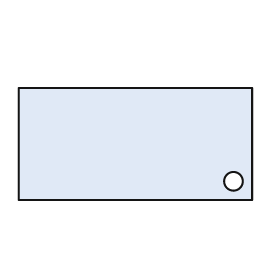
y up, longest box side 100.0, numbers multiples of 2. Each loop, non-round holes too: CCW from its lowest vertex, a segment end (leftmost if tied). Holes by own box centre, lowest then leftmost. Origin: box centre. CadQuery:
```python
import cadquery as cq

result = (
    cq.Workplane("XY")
    .moveTo(-50.0, -24.0)
    .lineTo(50.0, -24.0)
    .lineTo(50.0, 24.0)
    .lineTo(-50.0, 24.0)
    .close()
    .moveTo(42.0, -16.0)
    .circle(4.0)
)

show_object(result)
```